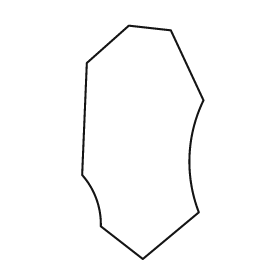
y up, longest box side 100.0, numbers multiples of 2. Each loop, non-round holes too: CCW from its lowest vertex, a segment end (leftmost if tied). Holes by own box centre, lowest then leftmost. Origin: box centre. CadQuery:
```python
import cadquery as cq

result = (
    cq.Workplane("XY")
    .moveTo(0.0, -50.0)
    .lineTo(24.0, -30.0)
    .threePointArc((20.0, -6.0), (26.0, 18.0))
    .lineTo(12.0, 48.0)
    .lineTo(-6.0, 50.0)
    .lineTo(-24.0, 34.0)
    .lineTo(-26.0, -14.0)
    .threePointArc((-20.0, -24.0), (-18.0, -36.0))
    .close()
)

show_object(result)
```